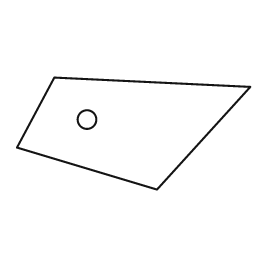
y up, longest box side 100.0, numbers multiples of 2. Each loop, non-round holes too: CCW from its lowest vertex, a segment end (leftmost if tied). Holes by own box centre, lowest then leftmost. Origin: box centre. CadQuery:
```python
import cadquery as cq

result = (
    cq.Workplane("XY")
    .moveTo(10.0, -24.0)
    .lineTo(50.0, 20.0)
    .lineTo(-34.0, 24.0)
    .lineTo(-50.0, -6.0)
    .close()
    .moveTo(-20.0, 6.0)
    .circle(4.0)
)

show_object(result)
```